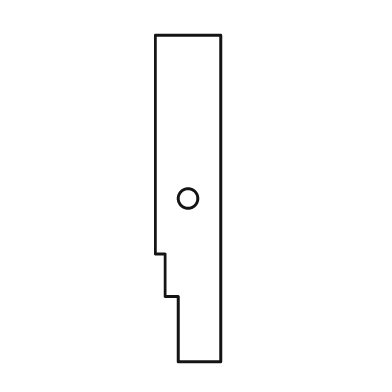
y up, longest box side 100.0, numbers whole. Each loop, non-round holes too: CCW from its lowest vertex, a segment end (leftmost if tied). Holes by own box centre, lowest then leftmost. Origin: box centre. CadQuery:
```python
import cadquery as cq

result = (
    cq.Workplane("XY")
    .moveTo(-3.0, -50.0)
    .lineTo(10.0, -50.0)
    .lineTo(10.0, 50.0)
    .lineTo(-10.0, 50.0)
    .lineTo(-10.0, -17.0)
    .lineTo(-7.0, -17.0)
    .lineTo(-7.0, -30.0)
    .lineTo(-3.0, -30.0)
    .close()
    .moveTo(0.0, 0.0)
    .circle(3.0)
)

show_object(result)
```